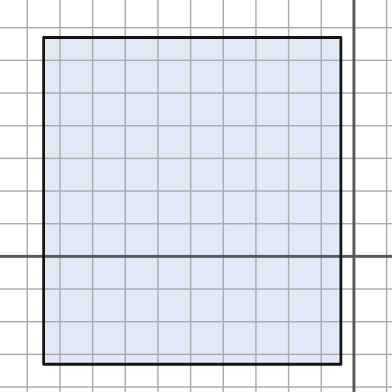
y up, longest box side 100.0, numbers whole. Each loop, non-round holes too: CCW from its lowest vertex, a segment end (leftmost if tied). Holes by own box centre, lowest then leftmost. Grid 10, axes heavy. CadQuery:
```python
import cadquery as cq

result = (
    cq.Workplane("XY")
    .moveTo(-95.0, -33.0)
    .lineTo(-4.0, -33.0)
    .lineTo(-4.0, 67.0)
    .lineTo(-95.0, 67.0)
    .close()
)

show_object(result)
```